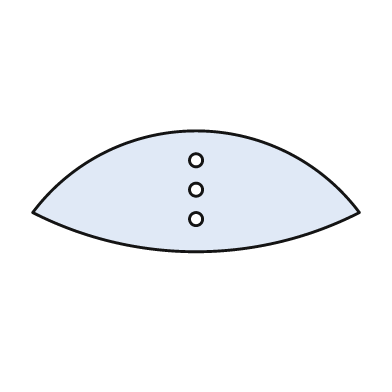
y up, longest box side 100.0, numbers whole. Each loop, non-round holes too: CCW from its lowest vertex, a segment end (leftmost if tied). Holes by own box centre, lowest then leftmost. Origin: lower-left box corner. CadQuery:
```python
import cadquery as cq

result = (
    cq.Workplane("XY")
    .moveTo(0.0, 12.0)
    .threePointArc((50.0, 0.0), (100.0, 12.0))
    .threePointArc((50.0, 37.0), (0.0, 12.0))
    .close()
    .moveTo(50.0, 10.0)
    .circle(2.0)
    .moveTo(50.0, 19.0)
    .circle(2.0)
    .moveTo(50.0, 28.0)
    .circle(2.0)
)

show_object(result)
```